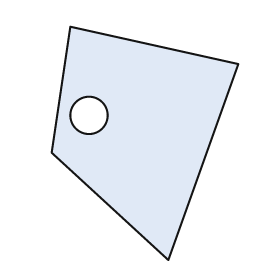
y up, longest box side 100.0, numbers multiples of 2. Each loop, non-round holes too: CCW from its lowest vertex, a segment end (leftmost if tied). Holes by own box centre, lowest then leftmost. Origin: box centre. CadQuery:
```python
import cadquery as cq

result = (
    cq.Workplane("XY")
    .moveTo(10.0, -50.0)
    .lineTo(40.0, 34.0)
    .lineTo(-32.0, 50.0)
    .lineTo(-40.0, -4.0)
    .close()
    .moveTo(-24.0, 12.0)
    .circle(8.0)
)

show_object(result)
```